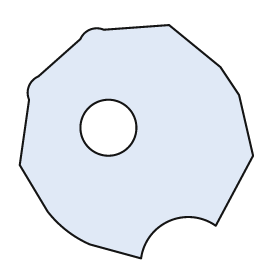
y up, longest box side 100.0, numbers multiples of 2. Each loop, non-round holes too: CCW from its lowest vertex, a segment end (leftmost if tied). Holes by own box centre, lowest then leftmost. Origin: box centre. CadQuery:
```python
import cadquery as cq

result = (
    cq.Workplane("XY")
    .moveTo(2.0, -50.0)
    .threePointArc((14.0, -34.0), (34.0, -36.0))
    .lineTo(50.0, -6.0)
    .lineTo(44.0, 20.0)
    .lineTo(36.0, 32.0)
    .lineTo(14.0, 50.0)
    .lineTo(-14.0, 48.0)
    .threePointArc((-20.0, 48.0), (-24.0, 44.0))
    .lineTo(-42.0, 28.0)
    .threePointArc((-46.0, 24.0), (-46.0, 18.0))
    .lineTo(-50.0, -10.0)
    .lineTo(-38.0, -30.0)
    .threePointArc((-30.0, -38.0), (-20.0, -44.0))
    .close()
    .moveTo(-12.0, 6.0)
    .circle(12.0)
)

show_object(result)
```